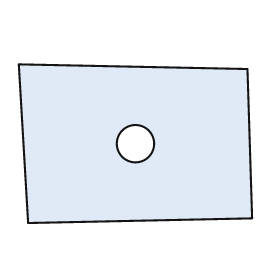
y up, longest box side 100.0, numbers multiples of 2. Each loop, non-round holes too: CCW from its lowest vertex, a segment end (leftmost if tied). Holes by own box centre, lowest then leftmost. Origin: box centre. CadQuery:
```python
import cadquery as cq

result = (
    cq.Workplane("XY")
    .moveTo(-46.0, -34.0)
    .lineTo(50.0, -32.0)
    .lineTo(48.0, 32.0)
    .lineTo(-50.0, 34.0)
    .close()
    .moveTo(0.0, 0.0)
    .circle(8.0)
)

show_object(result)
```